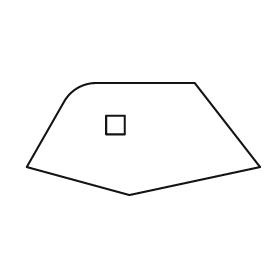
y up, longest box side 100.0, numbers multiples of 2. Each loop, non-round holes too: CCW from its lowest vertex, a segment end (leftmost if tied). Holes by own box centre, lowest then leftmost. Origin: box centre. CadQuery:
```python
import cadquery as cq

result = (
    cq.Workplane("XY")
    .moveTo(-6.0, -24.0)
    .lineTo(50.0, -12.0)
    .lineTo(22.0, 24.0)
    .lineTo(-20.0, 24.0)
    .threePointArc((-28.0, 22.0), (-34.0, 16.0))
    .lineTo(-50.0, -12.0)
    .close()
    .moveTo(-16.0, 2.0)
    .lineTo(-8.0, 2.0)
    .lineTo(-8.0, 10.0)
    .lineTo(-16.0, 10.0)
    .close()
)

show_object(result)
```